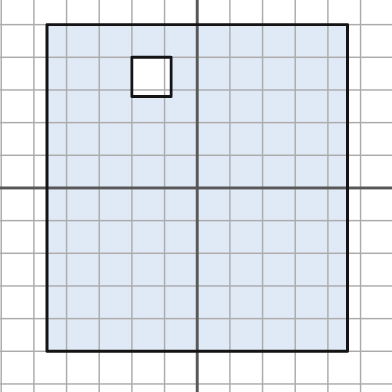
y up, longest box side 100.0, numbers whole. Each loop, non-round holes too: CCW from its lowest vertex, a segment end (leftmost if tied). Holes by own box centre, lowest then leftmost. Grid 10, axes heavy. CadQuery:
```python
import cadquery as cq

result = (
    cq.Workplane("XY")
    .moveTo(-46.0, -50.0)
    .lineTo(46.0, -50.0)
    .lineTo(46.0, 50.0)
    .lineTo(-46.0, 50.0)
    .close()
    .moveTo(-20.0, 28.0)
    .lineTo(-8.0, 28.0)
    .lineTo(-8.0, 40.0)
    .lineTo(-20.0, 40.0)
    .close()
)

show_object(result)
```